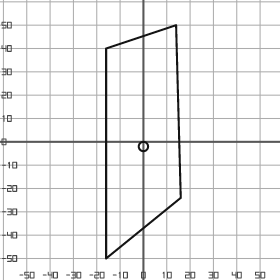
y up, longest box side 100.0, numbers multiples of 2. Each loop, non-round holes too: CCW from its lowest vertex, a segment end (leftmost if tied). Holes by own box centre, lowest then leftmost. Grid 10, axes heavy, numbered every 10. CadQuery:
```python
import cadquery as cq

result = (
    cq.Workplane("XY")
    .moveTo(-16.0, -50.0)
    .lineTo(16.0, -24.0)
    .lineTo(14.0, 50.0)
    .lineTo(-16.0, 40.0)
    .close()
    .moveTo(0.0, -2.0)
    .circle(2.0)
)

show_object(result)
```